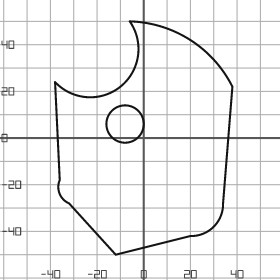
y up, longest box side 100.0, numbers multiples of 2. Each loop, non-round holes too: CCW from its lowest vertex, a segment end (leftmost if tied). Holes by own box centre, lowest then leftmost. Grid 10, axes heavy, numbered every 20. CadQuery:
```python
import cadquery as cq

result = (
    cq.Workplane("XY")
    .moveTo(-12.0, -50.0)
    .lineTo(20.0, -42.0)
    .threePointArc((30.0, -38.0), (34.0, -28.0))
    .lineTo(38.0, 22.0)
    .threePointArc((20.0, 42.0), (-6.0, 50.0))
    .threePointArc((-10.0, 22.0), (-38.0, 24.0))
    .lineTo(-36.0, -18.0)
    .threePointArc((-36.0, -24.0), (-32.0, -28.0))
    .close()
    .moveTo(-8.0, 6.0)
    .circle(8.0)
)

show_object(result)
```